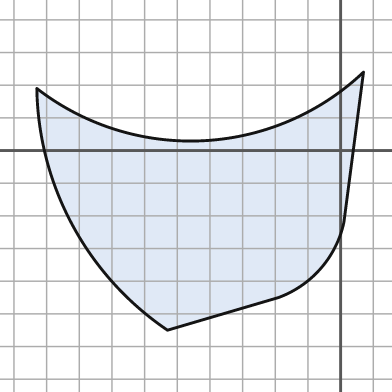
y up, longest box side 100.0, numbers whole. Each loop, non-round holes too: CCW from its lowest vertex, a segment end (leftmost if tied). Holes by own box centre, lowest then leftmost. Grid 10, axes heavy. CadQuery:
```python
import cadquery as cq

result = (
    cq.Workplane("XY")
    .moveTo(-53.0, -55.0)
    .lineTo(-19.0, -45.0)
    .threePointArc((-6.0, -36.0), (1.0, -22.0))
    .lineTo(7.0, 24.0)
    .threePointArc((-42.0, 3.0), (-93.0, 19.0))
    .threePointArc((-82.0, -23.0), (-53.0, -55.0))
    .close()
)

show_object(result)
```